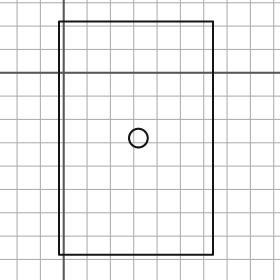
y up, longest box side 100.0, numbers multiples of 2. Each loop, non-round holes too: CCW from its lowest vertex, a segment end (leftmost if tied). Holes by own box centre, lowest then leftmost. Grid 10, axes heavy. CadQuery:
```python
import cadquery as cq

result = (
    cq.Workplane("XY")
    .moveTo(-2.0, -78.0)
    .lineTo(64.0, -78.0)
    .lineTo(64.0, 22.0)
    .lineTo(-2.0, 22.0)
    .close()
    .moveTo(32.0, -28.0)
    .circle(4.0)
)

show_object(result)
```